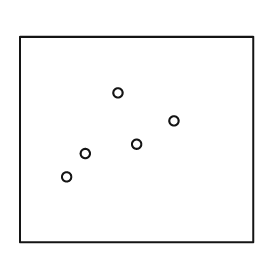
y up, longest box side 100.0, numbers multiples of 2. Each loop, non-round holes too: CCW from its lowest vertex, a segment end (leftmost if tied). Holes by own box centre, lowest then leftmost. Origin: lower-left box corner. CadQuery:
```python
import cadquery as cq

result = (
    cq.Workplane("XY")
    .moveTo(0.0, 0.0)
    .lineTo(100.0, 0.0)
    .lineTo(100.0, 88.0)
    .lineTo(0.0, 88.0)
    .close()
    .moveTo(20.0, 28.0)
    .circle(2.0)
    .moveTo(28.0, 38.0)
    .circle(2.0)
    .moveTo(50.0, 42.0)
    .circle(2.0)
    .moveTo(66.0, 52.0)
    .circle(2.0)
    .moveTo(42.0, 64.0)
    .circle(2.0)
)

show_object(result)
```